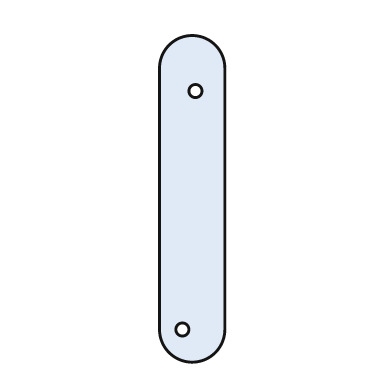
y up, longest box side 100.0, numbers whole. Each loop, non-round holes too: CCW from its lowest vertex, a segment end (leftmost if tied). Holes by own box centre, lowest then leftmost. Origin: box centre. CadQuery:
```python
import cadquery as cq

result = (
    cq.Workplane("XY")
    .moveTo(-10.0, -40.0)
    .threePointArc((0.0, -50.0), (10.0, -40.0))
    .lineTo(10.0, 40.0)
    .threePointArc((0.0, 50.0), (-10.0, 40.0))
    .close()
    .moveTo(-3.0, -40.0)
    .circle(2.0)
    .moveTo(1.0, 33.0)
    .circle(2.0)
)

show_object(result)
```